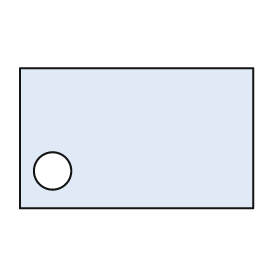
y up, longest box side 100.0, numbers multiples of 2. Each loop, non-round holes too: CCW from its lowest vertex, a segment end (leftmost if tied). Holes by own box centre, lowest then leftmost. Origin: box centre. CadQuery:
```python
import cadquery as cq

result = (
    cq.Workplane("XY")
    .moveTo(-50.0, -30.0)
    .lineTo(50.0, -30.0)
    .lineTo(50.0, 30.0)
    .lineTo(-50.0, 30.0)
    .close()
    .moveTo(-36.0, -14.0)
    .circle(8.0)
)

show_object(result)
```